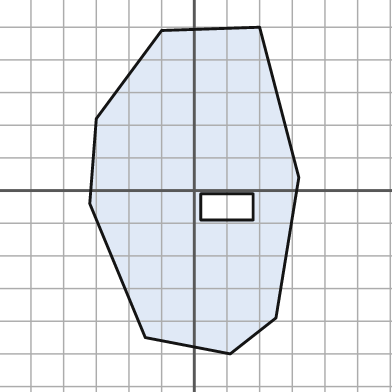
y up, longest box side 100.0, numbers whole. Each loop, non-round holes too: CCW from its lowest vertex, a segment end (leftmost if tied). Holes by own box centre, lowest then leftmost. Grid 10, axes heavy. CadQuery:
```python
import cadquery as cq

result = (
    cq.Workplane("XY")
    .moveTo(11.0, -50.0)
    .lineTo(25.0, -39.0)
    .lineTo(32.0, 4.0)
    .lineTo(20.0, 50.0)
    .lineTo(-10.0, 49.0)
    .lineTo(-30.0, 22.0)
    .lineTo(-32.0, -4.0)
    .lineTo(-15.0, -45.0)
    .close()
    .moveTo(2.0, -9.0)
    .lineTo(18.0, -9.0)
    .lineTo(18.0, -1.0)
    .lineTo(2.0, -1.0)
    .close()
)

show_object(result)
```